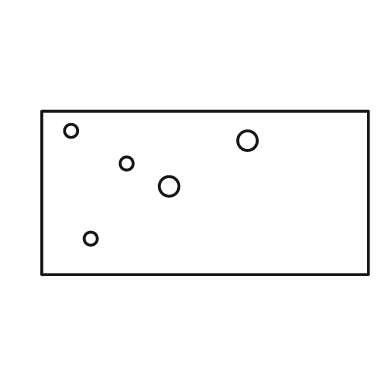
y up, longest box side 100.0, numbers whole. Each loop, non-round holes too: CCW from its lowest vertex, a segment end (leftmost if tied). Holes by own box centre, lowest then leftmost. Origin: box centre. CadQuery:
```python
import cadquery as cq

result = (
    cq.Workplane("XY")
    .moveTo(-50.0, -25.0)
    .lineTo(50.0, -25.0)
    .lineTo(50.0, 25.0)
    .lineTo(-50.0, 25.0)
    .close()
    .moveTo(-35.0, -14.0)
    .circle(2.0)
    .moveTo(-11.0, 2.0)
    .circle(3.0)
    .moveTo(-24.0, 9.0)
    .circle(2.0)
    .moveTo(13.0, 16.0)
    .circle(3.0)
    .moveTo(-41.0, 19.0)
    .circle(2.0)
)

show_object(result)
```